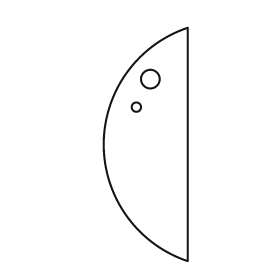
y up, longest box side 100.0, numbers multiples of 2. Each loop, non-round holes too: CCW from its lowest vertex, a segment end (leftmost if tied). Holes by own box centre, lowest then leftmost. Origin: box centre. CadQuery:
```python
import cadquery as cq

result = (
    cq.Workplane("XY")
    .moveTo(18.0, -50.0)
    .lineTo(18.0, 50.0)
    .threePointArc((-18.0, 0.0), (18.0, -50.0))
    .close()
    .moveTo(-4.0, 16.0)
    .circle(2.0)
    .moveTo(2.0, 28.0)
    .circle(4.0)
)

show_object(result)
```